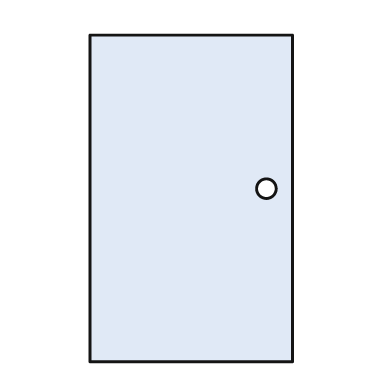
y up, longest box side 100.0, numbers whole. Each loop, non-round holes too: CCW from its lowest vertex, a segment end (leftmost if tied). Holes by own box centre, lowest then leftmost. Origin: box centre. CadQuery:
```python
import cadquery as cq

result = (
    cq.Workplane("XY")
    .moveTo(-31.0, -50.0)
    .lineTo(31.0, -50.0)
    .lineTo(31.0, 50.0)
    .lineTo(-31.0, 50.0)
    .close()
    .moveTo(23.0, 3.0)
    .circle(3.0)
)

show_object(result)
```